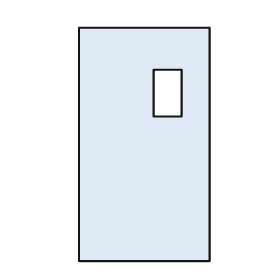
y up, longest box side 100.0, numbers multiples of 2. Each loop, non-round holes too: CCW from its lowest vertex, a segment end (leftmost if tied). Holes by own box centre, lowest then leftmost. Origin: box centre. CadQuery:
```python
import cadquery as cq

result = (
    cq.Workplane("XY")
    .moveTo(-28.0, -50.0)
    .lineTo(28.0, -50.0)
    .lineTo(28.0, 50.0)
    .lineTo(-28.0, 50.0)
    .close()
    .moveTo(4.0, 12.0)
    .lineTo(16.0, 12.0)
    .lineTo(16.0, 32.0)
    .lineTo(4.0, 32.0)
    .close()
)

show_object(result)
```